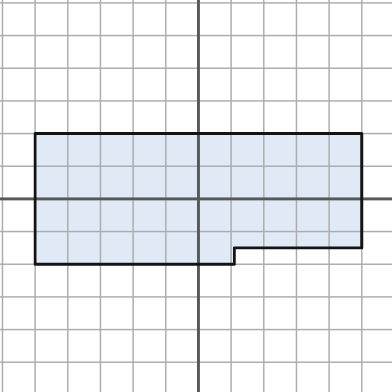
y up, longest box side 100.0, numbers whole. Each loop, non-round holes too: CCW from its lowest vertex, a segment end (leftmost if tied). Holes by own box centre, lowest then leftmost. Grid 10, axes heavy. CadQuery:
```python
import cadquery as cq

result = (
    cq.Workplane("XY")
    .moveTo(-50.0, -20.0)
    .lineTo(11.0, -20.0)
    .lineTo(11.0, -15.0)
    .lineTo(50.0, -15.0)
    .lineTo(50.0, 20.0)
    .lineTo(-50.0, 20.0)
    .close()
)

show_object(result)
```